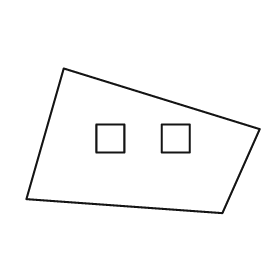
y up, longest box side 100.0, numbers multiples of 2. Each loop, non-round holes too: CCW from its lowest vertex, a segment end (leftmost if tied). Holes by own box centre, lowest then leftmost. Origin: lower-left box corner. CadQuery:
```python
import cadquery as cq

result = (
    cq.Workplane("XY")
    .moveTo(84.0, 0.0)
    .lineTo(100.0, 36.0)
    .lineTo(16.0, 62.0)
    .lineTo(0.0, 6.0)
    .close()
    .moveTo(30.0, 26.0)
    .lineTo(42.0, 26.0)
    .lineTo(42.0, 38.0)
    .lineTo(30.0, 38.0)
    .close()
    .moveTo(58.0, 26.0)
    .lineTo(70.0, 26.0)
    .lineTo(70.0, 38.0)
    .lineTo(58.0, 38.0)
    .close()
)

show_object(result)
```